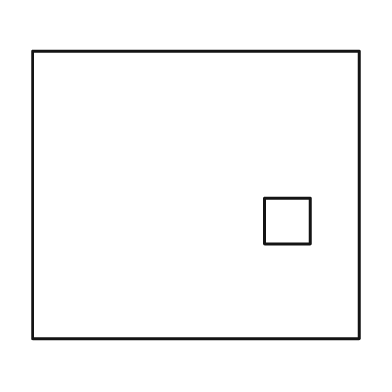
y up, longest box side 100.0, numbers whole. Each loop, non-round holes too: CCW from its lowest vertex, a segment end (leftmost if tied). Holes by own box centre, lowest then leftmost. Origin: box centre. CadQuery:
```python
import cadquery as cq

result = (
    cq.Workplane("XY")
    .moveTo(-50.0, -44.0)
    .lineTo(50.0, -44.0)
    .lineTo(50.0, 44.0)
    .lineTo(-50.0, 44.0)
    .close()
    .moveTo(21.0, -15.0)
    .lineTo(35.0, -15.0)
    .lineTo(35.0, -1.0)
    .lineTo(21.0, -1.0)
    .close()
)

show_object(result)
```